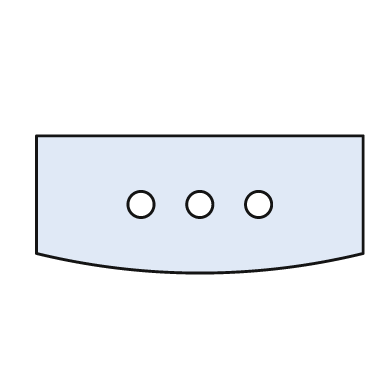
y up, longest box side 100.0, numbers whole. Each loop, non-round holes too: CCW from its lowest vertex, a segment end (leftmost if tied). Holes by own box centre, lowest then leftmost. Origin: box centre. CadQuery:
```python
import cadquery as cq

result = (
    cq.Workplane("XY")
    .moveTo(-50.0, -15.0)
    .threePointArc((0.0, -21.0), (50.0, -15.0))
    .lineTo(50.0, 21.0)
    .lineTo(-50.0, 21.0)
    .close()
    .moveTo(-18.0, 0.0)
    .circle(4.0)
    .moveTo(0.0, 0.0)
    .circle(4.0)
    .moveTo(18.0, 0.0)
    .circle(4.0)
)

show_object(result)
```